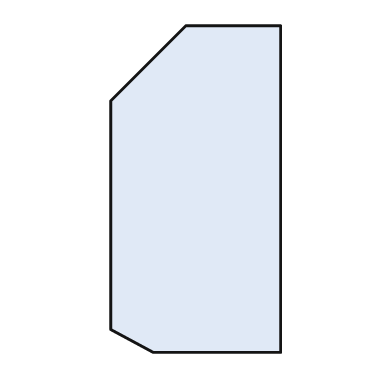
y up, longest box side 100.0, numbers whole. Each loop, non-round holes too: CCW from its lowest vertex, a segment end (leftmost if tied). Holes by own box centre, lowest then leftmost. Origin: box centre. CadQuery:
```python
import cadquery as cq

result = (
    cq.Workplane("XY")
    .moveTo(-13.0, -50.0)
    .lineTo(26.0, -50.0)
    .lineTo(26.0, 50.0)
    .lineTo(-3.0, 50.0)
    .lineTo(-26.0, 27.0)
    .lineTo(-26.0, -43.0)
    .close()
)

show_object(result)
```